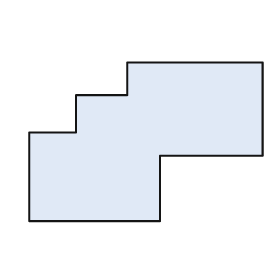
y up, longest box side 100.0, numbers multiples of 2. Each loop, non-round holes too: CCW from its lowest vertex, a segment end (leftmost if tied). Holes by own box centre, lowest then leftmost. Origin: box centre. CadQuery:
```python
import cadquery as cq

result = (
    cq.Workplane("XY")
    .moveTo(-50.0, -34.0)
    .lineTo(6.0, -34.0)
    .lineTo(6.0, -6.0)
    .lineTo(50.0, -6.0)
    .lineTo(50.0, 34.0)
    .lineTo(-8.0, 34.0)
    .lineTo(-8.0, 20.0)
    .lineTo(-30.0, 20.0)
    .lineTo(-30.0, 4.0)
    .lineTo(-50.0, 4.0)
    .close()
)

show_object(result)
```